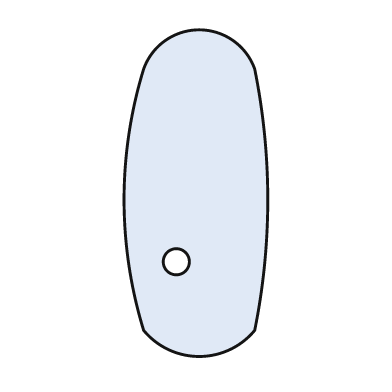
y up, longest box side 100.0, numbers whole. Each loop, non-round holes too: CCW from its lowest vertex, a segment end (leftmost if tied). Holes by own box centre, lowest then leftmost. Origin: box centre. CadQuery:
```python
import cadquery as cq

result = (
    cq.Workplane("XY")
    .moveTo(-16.0, -42.0)
    .threePointArc((1.0, -50.0), (18.0, -42.0))
    .threePointArc((22.0, -2.0), (18.0, 38.0))
    .threePointArc((1.0, 50.0), (-16.0, 38.0))
    .threePointArc((-22.0, -2.0), (-16.0, -42.0))
    .close()
    .moveTo(-6.0, -21.0)
    .circle(4.0)
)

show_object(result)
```